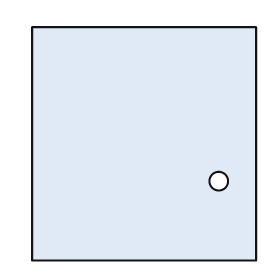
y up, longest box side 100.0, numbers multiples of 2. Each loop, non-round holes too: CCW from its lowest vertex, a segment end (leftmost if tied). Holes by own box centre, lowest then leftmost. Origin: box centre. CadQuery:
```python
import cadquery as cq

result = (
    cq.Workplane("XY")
    .moveTo(-48.0, -50.0)
    .lineTo(48.0, -50.0)
    .lineTo(48.0, 50.0)
    .lineTo(-48.0, 50.0)
    .close()
    .moveTo(32.0, -16.0)
    .circle(4.0)
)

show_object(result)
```